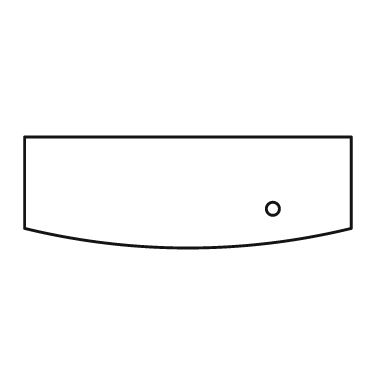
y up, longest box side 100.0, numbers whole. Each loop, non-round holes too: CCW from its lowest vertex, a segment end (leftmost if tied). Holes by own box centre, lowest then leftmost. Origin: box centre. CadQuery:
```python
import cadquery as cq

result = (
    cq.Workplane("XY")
    .moveTo(-50.0, -11.0)
    .threePointArc((0.0, -17.0), (50.0, -11.0))
    .lineTo(50.0, 17.0)
    .lineTo(-50.0, 17.0)
    .close()
    .moveTo(26.0, -5.0)
    .circle(2.0)
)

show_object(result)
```